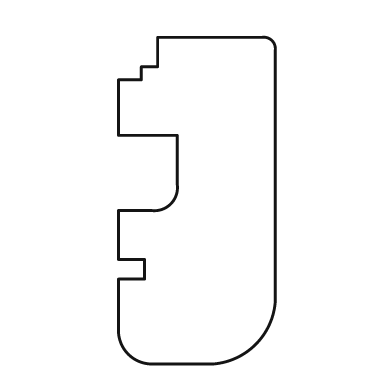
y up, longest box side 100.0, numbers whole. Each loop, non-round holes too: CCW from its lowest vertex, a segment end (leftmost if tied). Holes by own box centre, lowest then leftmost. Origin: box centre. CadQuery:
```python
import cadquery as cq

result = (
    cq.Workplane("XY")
    .moveTo(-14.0, -50.0)
    .lineTo(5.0, -50.0)
    .threePointArc((18.0, -44.0), (24.0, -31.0))
    .lineTo(24.0, 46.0)
    .threePointArc((23.0, 49.0), (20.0, 50.0))
    .lineTo(-12.0, 50.0)
    .lineTo(-12.0, 41.0)
    .lineTo(-17.0, 41.0)
    .lineTo(-17.0, 37.0)
    .lineTo(-24.0, 37.0)
    .lineTo(-24.0, 20.0)
    .lineTo(-6.0, 20.0)
    .lineTo(-6.0, 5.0)
    .threePointArc((-8.0, -1.0), (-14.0, -3.0))
    .lineTo(-24.0, -3.0)
    .lineTo(-24.0, -18.0)
    .lineTo(-16.0, -18.0)
    .lineTo(-16.0, -24.0)
    .lineTo(-24.0, -24.0)
    .lineTo(-24.0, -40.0)
    .threePointArc((-21.0, -47.0), (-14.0, -50.0))
    .close()
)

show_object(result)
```